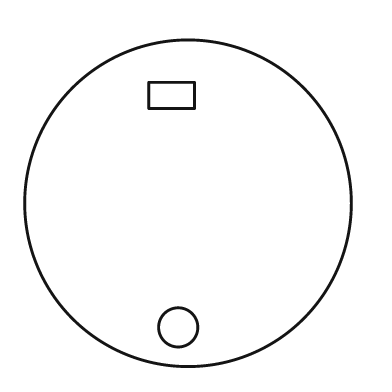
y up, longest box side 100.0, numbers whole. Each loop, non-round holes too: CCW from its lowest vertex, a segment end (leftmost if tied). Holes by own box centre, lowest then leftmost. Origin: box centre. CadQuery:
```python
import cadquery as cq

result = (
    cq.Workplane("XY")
    .moveTo(0.0, 0.0)
    .circle(50.0)
    .moveTo(-3.0, -38.0)
    .circle(6.0)
    .moveTo(-12.0, 29.0)
    .lineTo(2.0, 29.0)
    .lineTo(2.0, 37.0)
    .lineTo(-12.0, 37.0)
    .close()
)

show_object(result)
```